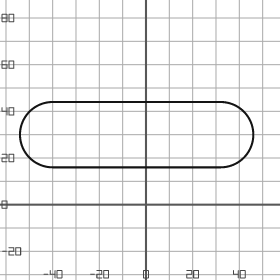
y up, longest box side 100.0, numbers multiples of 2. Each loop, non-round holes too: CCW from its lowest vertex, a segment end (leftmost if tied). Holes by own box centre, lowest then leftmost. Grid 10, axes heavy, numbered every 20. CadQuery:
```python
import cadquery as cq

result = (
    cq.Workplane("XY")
    .moveTo(-40.0, 16.0)
    .lineTo(32.0, 16.0)
    .threePointArc((46.0, 30.0), (32.0, 44.0))
    .lineTo(-40.0, 44.0)
    .threePointArc((-54.0, 30.0), (-40.0, 16.0))
    .close()
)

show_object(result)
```